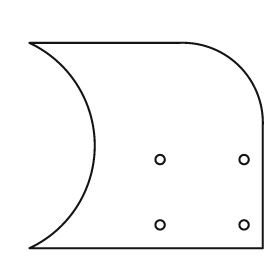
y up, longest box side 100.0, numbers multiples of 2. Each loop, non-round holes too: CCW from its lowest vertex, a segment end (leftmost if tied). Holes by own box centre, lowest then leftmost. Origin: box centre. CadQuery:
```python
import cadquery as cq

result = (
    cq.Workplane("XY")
    .moveTo(-50.0, -44.0)
    .lineTo(50.0, -44.0)
    .lineTo(50.0, 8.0)
    .threePointArc((40.0, 34.0), (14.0, 44.0))
    .lineTo(-50.0, 44.0)
    .threePointArc((-22.0, 0.0), (-50.0, -44.0))
    .close()
    .moveTo(6.0, -34.0)
    .circle(2.0)
    .moveTo(42.0, -34.0)
    .circle(2.0)
    .moveTo(6.0, -6.0)
    .circle(2.0)
    .moveTo(42.0, -6.0)
    .circle(2.0)
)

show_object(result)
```